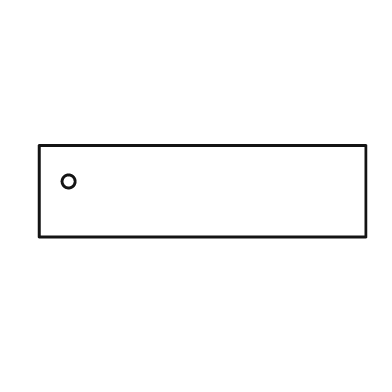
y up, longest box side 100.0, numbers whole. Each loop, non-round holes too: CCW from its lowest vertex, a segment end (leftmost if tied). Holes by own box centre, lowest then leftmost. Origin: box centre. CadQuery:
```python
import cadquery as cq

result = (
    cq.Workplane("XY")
    .moveTo(-50.0, -14.0)
    .lineTo(50.0, -14.0)
    .lineTo(50.0, 14.0)
    .lineTo(-50.0, 14.0)
    .close()
    .moveTo(-41.0, 3.0)
    .circle(2.0)
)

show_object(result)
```